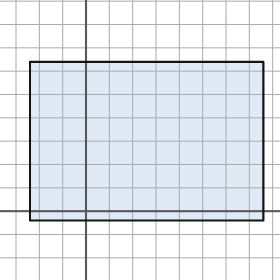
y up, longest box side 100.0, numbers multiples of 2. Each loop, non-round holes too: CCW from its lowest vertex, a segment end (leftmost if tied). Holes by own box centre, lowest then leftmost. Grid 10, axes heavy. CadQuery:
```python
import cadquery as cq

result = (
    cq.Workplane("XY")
    .moveTo(-24.0, -4.0)
    .lineTo(76.0, -4.0)
    .lineTo(76.0, 64.0)
    .lineTo(-24.0, 64.0)
    .close()
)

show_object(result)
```